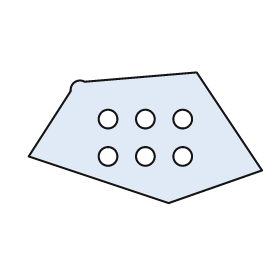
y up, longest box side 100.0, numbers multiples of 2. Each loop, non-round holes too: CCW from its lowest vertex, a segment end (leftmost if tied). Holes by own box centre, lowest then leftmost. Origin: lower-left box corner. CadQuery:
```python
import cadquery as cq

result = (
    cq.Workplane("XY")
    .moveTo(60.0, 0.0)
    .lineTo(100.0, 14.0)
    .lineTo(72.0, 56.0)
    .lineTo(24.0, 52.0)
    .threePointArc((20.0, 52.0), (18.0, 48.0))
    .lineTo(0.0, 20.0)
    .close()
    .moveTo(34.0, 20.0)
    .circle(4.0)
    .moveTo(50.0, 20.0)
    .circle(4.0)
    .moveTo(66.0, 20.0)
    .circle(4.0)
    .moveTo(34.0, 36.0)
    .circle(4.0)
    .moveTo(50.0, 36.0)
    .circle(4.0)
    .moveTo(66.0, 36.0)
    .circle(4.0)
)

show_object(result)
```